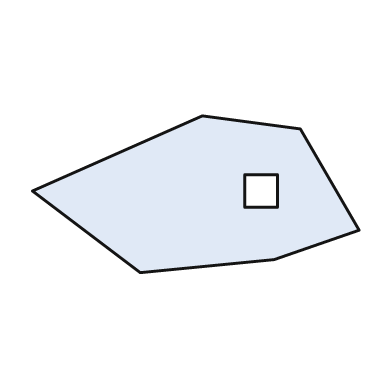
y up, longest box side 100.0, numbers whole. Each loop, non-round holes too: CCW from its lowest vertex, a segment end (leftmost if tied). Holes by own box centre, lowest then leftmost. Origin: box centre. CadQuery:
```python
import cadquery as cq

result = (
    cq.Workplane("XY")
    .moveTo(-17.0, -24.0)
    .lineTo(24.0, -20.0)
    .lineTo(50.0, -11.0)
    .lineTo(32.0, 20.0)
    .lineTo(2.0, 24.0)
    .lineTo(-50.0, 1.0)
    .close()
    .moveTo(15.0, -4.0)
    .lineTo(25.0, -4.0)
    .lineTo(25.0, 6.0)
    .lineTo(15.0, 6.0)
    .close()
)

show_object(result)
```